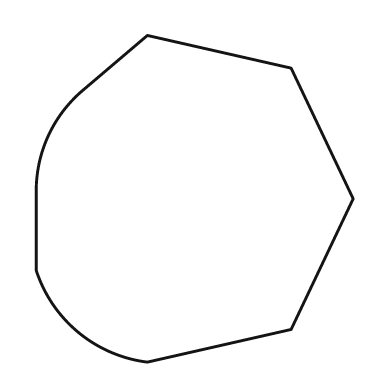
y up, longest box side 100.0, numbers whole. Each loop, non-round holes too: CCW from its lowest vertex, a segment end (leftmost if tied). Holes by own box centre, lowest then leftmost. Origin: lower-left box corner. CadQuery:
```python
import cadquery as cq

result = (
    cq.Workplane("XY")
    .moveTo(34.0, 0.0)
    .lineTo(78.0, 10.0)
    .lineTo(97.0, 50.0)
    .lineTo(78.0, 90.0)
    .lineTo(34.0, 100.0)
    .lineTo(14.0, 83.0)
    .threePointArc((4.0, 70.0), (0.0, 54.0))
    .lineTo(0.0, 28.0)
    .threePointArc((13.0, 9.0), (34.0, 0.0))
    .close()
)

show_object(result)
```